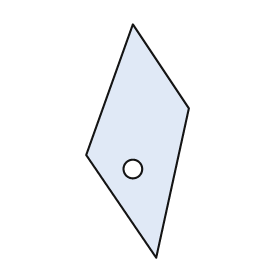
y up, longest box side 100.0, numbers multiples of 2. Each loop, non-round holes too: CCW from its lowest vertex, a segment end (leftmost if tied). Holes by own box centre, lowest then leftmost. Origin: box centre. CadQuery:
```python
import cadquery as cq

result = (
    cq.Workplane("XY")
    .moveTo(8.0, -50.0)
    .lineTo(22.0, 14.0)
    .lineTo(-2.0, 50.0)
    .lineTo(-22.0, -6.0)
    .close()
    .moveTo(-2.0, -12.0)
    .circle(4.0)
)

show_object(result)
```